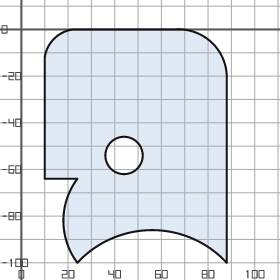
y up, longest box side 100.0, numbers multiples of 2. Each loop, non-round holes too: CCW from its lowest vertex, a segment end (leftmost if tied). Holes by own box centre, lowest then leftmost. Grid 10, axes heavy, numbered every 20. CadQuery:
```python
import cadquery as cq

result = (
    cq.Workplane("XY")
    .moveTo(24.0, -100.0)
    .threePointArc((56.0, -86.0), (88.0, -100.0))
    .lineTo(88.0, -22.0)
    .threePointArc((82.0, -6.0), (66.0, 0.0))
    .lineTo(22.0, 0.0)
    .threePointArc((14.0, -4.0), (10.0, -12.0))
    .lineTo(10.0, -64.0)
    .lineTo(24.0, -64.0)
    .threePointArc((18.0, -82.0), (24.0, -100.0))
    .close()
    .moveTo(44.0, -54.0)
    .circle(8.0)
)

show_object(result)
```